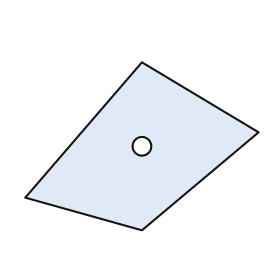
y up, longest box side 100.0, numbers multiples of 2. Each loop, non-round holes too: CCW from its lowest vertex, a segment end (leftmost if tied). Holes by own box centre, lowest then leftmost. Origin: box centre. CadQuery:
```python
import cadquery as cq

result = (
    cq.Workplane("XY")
    .moveTo(0.0, -36.0)
    .lineTo(50.0, 6.0)
    .lineTo(0.0, 36.0)
    .lineTo(-50.0, -22.0)
    .close()
    .moveTo(0.0, 0.0)
    .circle(4.0)
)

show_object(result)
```